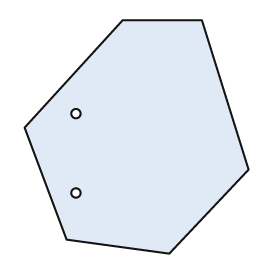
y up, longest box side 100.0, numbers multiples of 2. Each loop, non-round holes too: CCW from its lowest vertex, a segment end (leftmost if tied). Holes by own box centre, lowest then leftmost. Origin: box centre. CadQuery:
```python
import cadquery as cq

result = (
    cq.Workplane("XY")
    .moveTo(14.0, -50.0)
    .lineTo(48.0, -14.0)
    .lineTo(28.0, 50.0)
    .lineTo(-6.0, 50.0)
    .lineTo(-48.0, 4.0)
    .lineTo(-30.0, -44.0)
    .close()
    .moveTo(-26.0, -24.0)
    .circle(2.0)
    .moveTo(-26.0, 10.0)
    .circle(2.0)
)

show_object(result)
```